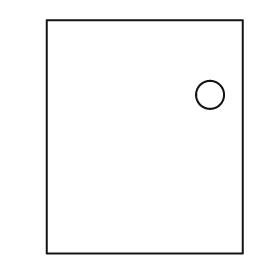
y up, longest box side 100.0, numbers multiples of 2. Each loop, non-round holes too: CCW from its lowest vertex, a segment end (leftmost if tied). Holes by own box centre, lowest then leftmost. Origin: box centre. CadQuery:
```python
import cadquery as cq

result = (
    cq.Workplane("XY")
    .moveTo(-42.0, -50.0)
    .lineTo(42.0, -50.0)
    .lineTo(42.0, 50.0)
    .lineTo(-42.0, 50.0)
    .close()
    .moveTo(28.0, 18.0)
    .circle(6.0)
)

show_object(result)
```